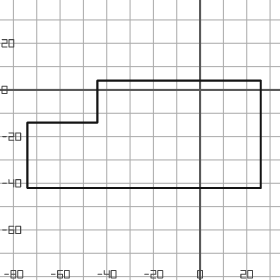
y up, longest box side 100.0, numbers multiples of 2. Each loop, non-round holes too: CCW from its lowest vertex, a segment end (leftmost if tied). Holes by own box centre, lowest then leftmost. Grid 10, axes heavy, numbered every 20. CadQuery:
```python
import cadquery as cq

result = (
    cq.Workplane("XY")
    .moveTo(-74.0, -42.0)
    .lineTo(26.0, -42.0)
    .lineTo(26.0, 4.0)
    .lineTo(-44.0, 4.0)
    .lineTo(-44.0, -14.0)
    .lineTo(-74.0, -14.0)
    .close()
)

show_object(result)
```